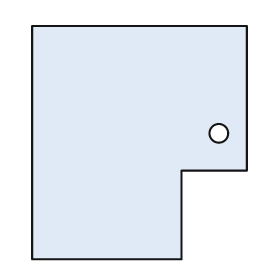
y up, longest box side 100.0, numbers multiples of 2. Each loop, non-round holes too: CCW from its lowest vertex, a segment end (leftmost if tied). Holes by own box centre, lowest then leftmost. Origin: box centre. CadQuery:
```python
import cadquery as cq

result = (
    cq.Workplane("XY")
    .moveTo(-46.0, -50.0)
    .lineTo(18.0, -50.0)
    .lineTo(18.0, -12.0)
    .lineTo(46.0, -12.0)
    .lineTo(46.0, 50.0)
    .lineTo(-46.0, 50.0)
    .close()
    .moveTo(34.0, 4.0)
    .circle(4.0)
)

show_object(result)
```